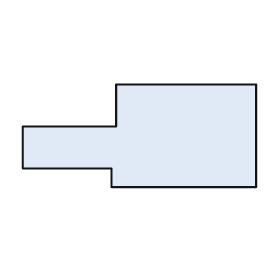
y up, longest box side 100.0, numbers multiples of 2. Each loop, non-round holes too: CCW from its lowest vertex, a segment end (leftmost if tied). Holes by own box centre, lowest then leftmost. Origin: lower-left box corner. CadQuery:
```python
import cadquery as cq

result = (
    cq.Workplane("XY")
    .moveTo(38.0, 0.0)
    .lineTo(100.0, 0.0)
    .lineTo(100.0, 44.0)
    .lineTo(40.0, 44.0)
    .lineTo(40.0, 26.0)
    .lineTo(0.0, 26.0)
    .lineTo(0.0, 8.0)
    .lineTo(38.0, 8.0)
    .close()
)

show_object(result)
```